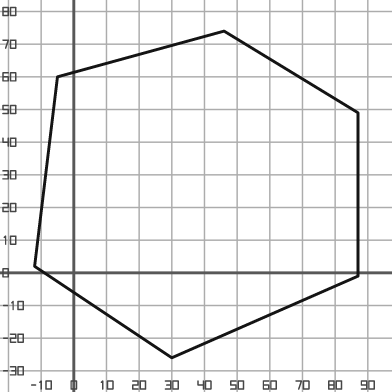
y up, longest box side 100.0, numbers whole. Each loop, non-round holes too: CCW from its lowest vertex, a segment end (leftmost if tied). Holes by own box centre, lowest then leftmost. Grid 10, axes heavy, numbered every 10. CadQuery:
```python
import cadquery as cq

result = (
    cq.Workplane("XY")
    .moveTo(30.0, -26.0)
    .lineTo(87.0, -1.0)
    .lineTo(87.0, 49.0)
    .lineTo(46.0, 74.0)
    .lineTo(-5.0, 60.0)
    .lineTo(-12.0, 2.0)
    .close()
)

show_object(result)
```